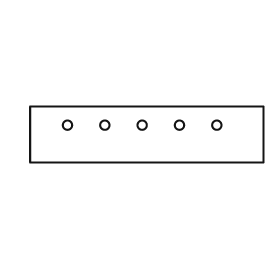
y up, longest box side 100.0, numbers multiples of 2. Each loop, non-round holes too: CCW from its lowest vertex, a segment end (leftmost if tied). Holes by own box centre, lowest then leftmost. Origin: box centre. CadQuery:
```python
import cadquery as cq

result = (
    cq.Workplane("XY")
    .moveTo(-50.0, -12.0)
    .lineTo(50.0, -12.0)
    .lineTo(50.0, 12.0)
    .lineTo(-50.0, 12.0)
    .close()
    .moveTo(-34.0, 4.0)
    .circle(2.0)
    .moveTo(-18.0, 4.0)
    .circle(2.0)
    .moveTo(-2.0, 4.0)
    .circle(2.0)
    .moveTo(14.0, 4.0)
    .circle(2.0)
    .moveTo(30.0, 4.0)
    .circle(2.0)
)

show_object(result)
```